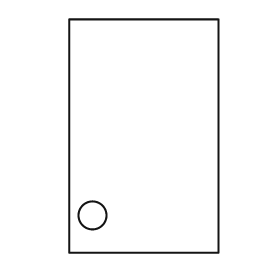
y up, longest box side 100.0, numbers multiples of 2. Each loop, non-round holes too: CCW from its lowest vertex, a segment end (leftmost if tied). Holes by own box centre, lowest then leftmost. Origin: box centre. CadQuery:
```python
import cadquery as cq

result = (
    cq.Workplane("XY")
    .moveTo(-32.0, -50.0)
    .lineTo(32.0, -50.0)
    .lineTo(32.0, 50.0)
    .lineTo(-32.0, 50.0)
    .close()
    .moveTo(-22.0, -34.0)
    .circle(6.0)
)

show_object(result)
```